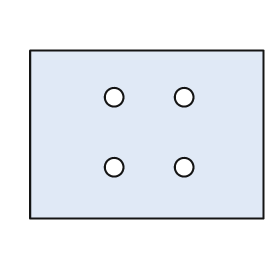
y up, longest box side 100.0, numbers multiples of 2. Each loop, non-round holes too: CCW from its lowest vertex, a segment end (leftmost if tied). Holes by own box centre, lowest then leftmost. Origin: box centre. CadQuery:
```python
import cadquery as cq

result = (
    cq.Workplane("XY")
    .moveTo(-50.0, -36.0)
    .lineTo(50.0, -36.0)
    .lineTo(50.0, 36.0)
    .lineTo(-50.0, 36.0)
    .close()
    .moveTo(-14.0, -14.0)
    .circle(4.0)
    .moveTo(16.0, -14.0)
    .circle(4.0)
    .moveTo(-14.0, 16.0)
    .circle(4.0)
    .moveTo(16.0, 16.0)
    .circle(4.0)
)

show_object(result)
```